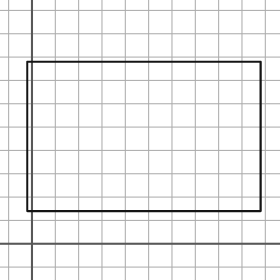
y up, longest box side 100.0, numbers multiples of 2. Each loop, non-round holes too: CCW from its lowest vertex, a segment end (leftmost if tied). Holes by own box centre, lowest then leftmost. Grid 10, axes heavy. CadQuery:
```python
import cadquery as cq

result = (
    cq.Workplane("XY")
    .moveTo(-2.0, 14.0)
    .lineTo(98.0, 14.0)
    .lineTo(98.0, 78.0)
    .lineTo(-2.0, 78.0)
    .close()
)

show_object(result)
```